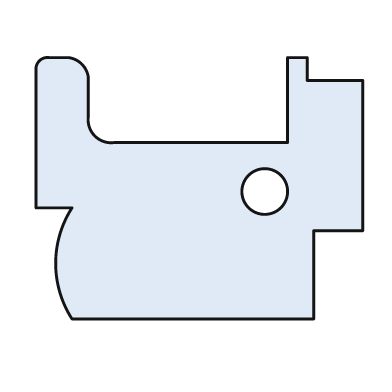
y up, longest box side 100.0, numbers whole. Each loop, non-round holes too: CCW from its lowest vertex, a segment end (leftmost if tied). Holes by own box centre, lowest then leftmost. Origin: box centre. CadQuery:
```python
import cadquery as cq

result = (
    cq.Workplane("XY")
    .moveTo(-39.0, -40.0)
    .lineTo(35.0, -40.0)
    .lineTo(35.0, -13.0)
    .lineTo(50.0, -13.0)
    .lineTo(50.0, 33.0)
    .lineTo(33.0, 33.0)
    .lineTo(33.0, 40.0)
    .lineTo(27.0, 40.0)
    .lineTo(27.0, 14.0)
    .lineTo(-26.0, 14.0)
    .threePointArc((-32.0, 16.0), (-34.0, 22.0))
    .lineTo(-34.0, 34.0)
    .threePointArc((-36.0, 38.0), (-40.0, 40.0))
    .lineTo(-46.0, 40.0)
    .threePointArc((-49.0, 39.0), (-50.0, 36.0))
    .lineTo(-50.0, -6.0)
    .lineTo(-39.0, -6.0)
    .threePointArc((-44.0, -23.0), (-39.0, -40.0))
    .close()
    .moveTo(20.0, -1.0)
    .circle(7.0)
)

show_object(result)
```